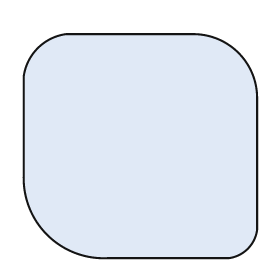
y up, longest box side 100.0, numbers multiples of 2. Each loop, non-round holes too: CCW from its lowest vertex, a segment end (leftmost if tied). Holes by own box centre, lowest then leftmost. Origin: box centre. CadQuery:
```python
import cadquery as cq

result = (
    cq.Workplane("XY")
    .moveTo(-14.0, -48.0)
    .lineTo(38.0, -48.0)
    .threePointArc((46.0, -44.0), (50.0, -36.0))
    .lineTo(50.0, 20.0)
    .threePointArc((42.0, 40.0), (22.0, 48.0))
    .lineTo(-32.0, 48.0)
    .threePointArc((-44.0, 42.0), (-50.0, 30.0))
    .lineTo(-50.0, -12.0)
    .threePointArc((-40.0, -38.0), (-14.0, -48.0))
    .close()
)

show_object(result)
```